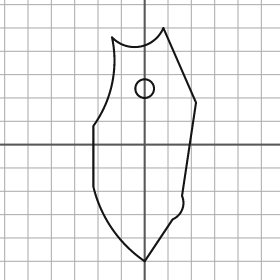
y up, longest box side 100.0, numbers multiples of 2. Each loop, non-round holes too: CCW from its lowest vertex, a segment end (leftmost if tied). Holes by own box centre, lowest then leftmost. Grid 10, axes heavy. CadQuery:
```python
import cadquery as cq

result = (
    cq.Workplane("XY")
    .moveTo(0.0, -50.0)
    .lineTo(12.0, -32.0)
    .threePointArc((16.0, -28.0), (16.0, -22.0))
    .lineTo(22.0, 18.0)
    .lineTo(8.0, 50.0)
    .threePointArc((-2.0, 42.0), (-14.0, 46.0))
    .threePointArc((-14.0, 26.0), (-22.0, 8.0))
    .lineTo(-22.0, -18.0)
    .threePointArc((-14.0, -36.0), (0.0, -50.0))
    .close()
    .moveTo(0.0, 24.0)
    .circle(4.0)
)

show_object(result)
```